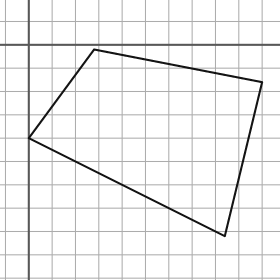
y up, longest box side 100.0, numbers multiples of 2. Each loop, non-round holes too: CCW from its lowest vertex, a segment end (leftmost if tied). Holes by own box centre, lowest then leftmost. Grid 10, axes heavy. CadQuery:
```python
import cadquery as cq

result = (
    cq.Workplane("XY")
    .moveTo(84.0, -82.0)
    .lineTo(100.0, -16.0)
    .lineTo(28.0, -2.0)
    .lineTo(0.0, -40.0)
    .close()
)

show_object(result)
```